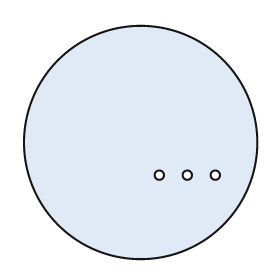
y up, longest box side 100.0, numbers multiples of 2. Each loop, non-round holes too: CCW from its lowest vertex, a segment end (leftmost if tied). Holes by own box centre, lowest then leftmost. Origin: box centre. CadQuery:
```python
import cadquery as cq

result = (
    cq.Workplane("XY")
    .moveTo(0.0, 0.0)
    .circle(50.0)
    .moveTo(8.0, -14.0)
    .circle(2.0)
    .moveTo(20.0, -14.0)
    .circle(2.0)
    .moveTo(32.0, -14.0)
    .circle(2.0)
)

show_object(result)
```